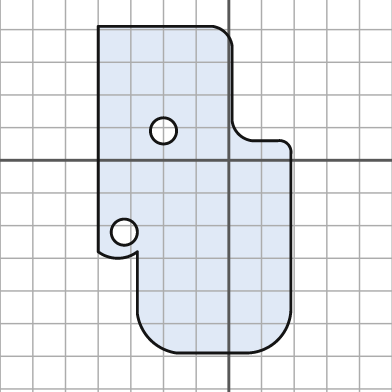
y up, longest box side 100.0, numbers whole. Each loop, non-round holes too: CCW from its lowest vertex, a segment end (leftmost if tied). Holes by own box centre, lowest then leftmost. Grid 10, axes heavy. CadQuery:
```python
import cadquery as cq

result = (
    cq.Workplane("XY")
    .moveTo(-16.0, -59.0)
    .lineTo(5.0, -59.0)
    .threePointArc((15.0, -55.0), (19.0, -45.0))
    .lineTo(19.0, 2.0)
    .threePointArc((18.0, 5.0), (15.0, 6.0))
    .lineTo(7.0, 6.0)
    .threePointArc((3.0, 8.0), (1.0, 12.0))
    .lineTo(1.0, 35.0)
    .threePointArc((-1.0, 39.0), (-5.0, 41.0))
    .lineTo(-40.0, 41.0)
    .lineTo(-40.0, -28.0)
    .threePointArc((-34.0, -30.0), (-28.0, -28.0))
    .lineTo(-28.0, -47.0)
    .threePointArc((-24.0, -55.0), (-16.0, -59.0))
    .close()
    .moveTo(-32.0, -22.0)
    .circle(4.0)
    .moveTo(-20.0, 9.0)
    .circle(4.0)
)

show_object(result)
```